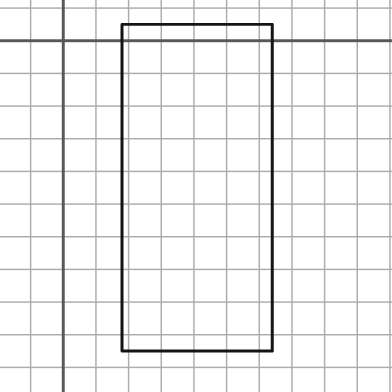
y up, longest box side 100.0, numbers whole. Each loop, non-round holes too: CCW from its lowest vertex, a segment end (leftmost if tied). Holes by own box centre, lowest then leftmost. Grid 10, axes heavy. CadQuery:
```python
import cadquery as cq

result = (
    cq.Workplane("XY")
    .moveTo(18.0, -95.0)
    .lineTo(64.0, -95.0)
    .lineTo(64.0, 5.0)
    .lineTo(18.0, 5.0)
    .close()
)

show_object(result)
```